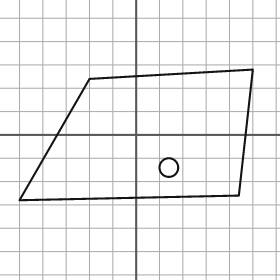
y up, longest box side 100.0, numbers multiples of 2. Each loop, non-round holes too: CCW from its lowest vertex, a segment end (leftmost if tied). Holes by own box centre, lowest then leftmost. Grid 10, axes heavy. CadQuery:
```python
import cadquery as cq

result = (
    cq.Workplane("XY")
    .moveTo(-50.0, -28.0)
    .lineTo(44.0, -26.0)
    .lineTo(50.0, 28.0)
    .lineTo(-20.0, 24.0)
    .close()
    .moveTo(14.0, -14.0)
    .circle(4.0)
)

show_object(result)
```